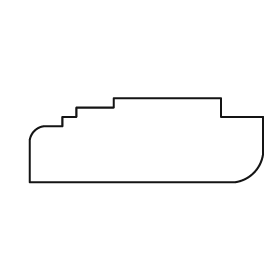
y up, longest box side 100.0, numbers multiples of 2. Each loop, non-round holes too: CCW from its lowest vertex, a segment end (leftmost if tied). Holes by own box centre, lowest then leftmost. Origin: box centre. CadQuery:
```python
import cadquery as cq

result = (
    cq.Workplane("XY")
    .moveTo(-50.0, -18.0)
    .lineTo(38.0, -18.0)
    .threePointArc((46.0, -14.0), (50.0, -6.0))
    .lineTo(50.0, 10.0)
    .lineTo(32.0, 10.0)
    .lineTo(32.0, 18.0)
    .lineTo(-14.0, 18.0)
    .lineTo(-14.0, 14.0)
    .lineTo(-30.0, 14.0)
    .lineTo(-30.0, 10.0)
    .lineTo(-36.0, 10.0)
    .lineTo(-36.0, 6.0)
    .lineTo(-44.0, 6.0)
    .threePointArc((-48.0, 4.0), (-50.0, 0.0))
    .close()
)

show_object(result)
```